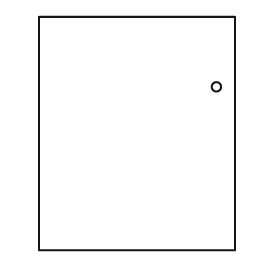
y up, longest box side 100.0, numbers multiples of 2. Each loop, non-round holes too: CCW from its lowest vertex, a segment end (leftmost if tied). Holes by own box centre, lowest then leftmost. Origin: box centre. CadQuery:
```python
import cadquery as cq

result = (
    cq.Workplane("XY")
    .moveTo(-42.0, -50.0)
    .lineTo(42.0, -50.0)
    .lineTo(42.0, 50.0)
    .lineTo(-42.0, 50.0)
    .close()
    .moveTo(34.0, 20.0)
    .circle(2.0)
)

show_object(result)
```